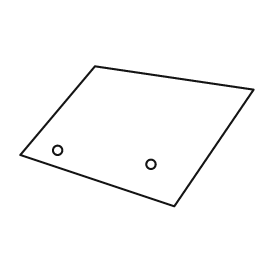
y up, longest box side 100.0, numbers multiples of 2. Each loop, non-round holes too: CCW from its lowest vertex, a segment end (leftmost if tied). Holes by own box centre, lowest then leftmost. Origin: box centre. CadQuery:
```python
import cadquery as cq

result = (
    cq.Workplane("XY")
    .moveTo(16.0, -30.0)
    .lineTo(50.0, 20.0)
    .lineTo(-18.0, 30.0)
    .lineTo(-50.0, -8.0)
    .close()
    .moveTo(6.0, -12.0)
    .circle(2.0)
    .moveTo(-34.0, -6.0)
    .circle(2.0)
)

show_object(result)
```